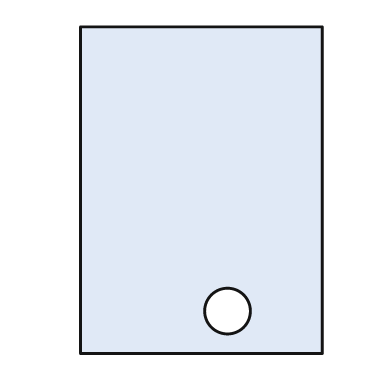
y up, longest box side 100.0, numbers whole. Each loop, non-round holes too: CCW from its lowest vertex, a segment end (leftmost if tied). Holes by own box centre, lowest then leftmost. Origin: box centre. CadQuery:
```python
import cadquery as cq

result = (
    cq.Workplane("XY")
    .moveTo(-37.0, -50.0)
    .lineTo(37.0, -50.0)
    .lineTo(37.0, 50.0)
    .lineTo(-37.0, 50.0)
    .close()
    .moveTo(8.0, -37.0)
    .circle(7.0)
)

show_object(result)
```